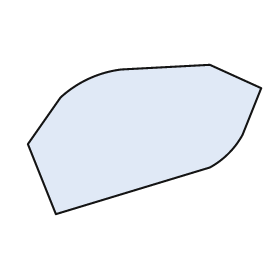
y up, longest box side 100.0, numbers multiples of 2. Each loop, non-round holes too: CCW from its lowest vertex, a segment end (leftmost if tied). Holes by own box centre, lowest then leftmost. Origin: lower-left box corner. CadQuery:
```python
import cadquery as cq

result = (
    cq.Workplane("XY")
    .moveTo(12.0, 0.0)
    .lineTo(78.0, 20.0)
    .threePointArc((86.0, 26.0), (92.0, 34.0))
    .lineTo(100.0, 54.0)
    .lineTo(78.0, 64.0)
    .lineTo(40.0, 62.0)
    .threePointArc((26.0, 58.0), (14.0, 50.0))
    .lineTo(0.0, 30.0)
    .close()
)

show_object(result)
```